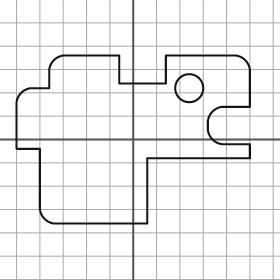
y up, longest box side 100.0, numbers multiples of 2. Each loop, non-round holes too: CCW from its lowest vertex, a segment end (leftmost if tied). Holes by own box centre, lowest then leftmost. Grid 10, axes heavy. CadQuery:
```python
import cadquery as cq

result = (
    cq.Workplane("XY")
    .moveTo(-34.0, -36.0)
    .lineTo(6.0, -36.0)
    .lineTo(6.0, -8.0)
    .lineTo(50.0, -8.0)
    .lineTo(50.0, -2.0)
    .lineTo(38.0, -2.0)
    .threePointArc((34.0, 0.0), (32.0, 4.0))
    .lineTo(32.0, 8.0)
    .threePointArc((34.0, 12.0), (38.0, 14.0))
    .lineTo(50.0, 14.0)
    .lineTo(50.0, 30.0)
    .threePointArc((48.0, 34.0), (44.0, 36.0))
    .lineTo(14.0, 36.0)
    .lineTo(14.0, 24.0)
    .lineTo(-6.0, 24.0)
    .lineTo(-6.0, 36.0)
    .lineTo(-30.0, 36.0)
    .threePointArc((-34.0, 34.0), (-36.0, 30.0))
    .lineTo(-36.0, 22.0)
    .lineTo(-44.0, 22.0)
    .threePointArc((-48.0, 20.0), (-50.0, 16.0))
    .lineTo(-50.0, -4.0)
    .lineTo(-40.0, -4.0)
    .lineTo(-40.0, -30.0)
    .threePointArc((-38.0, -34.0), (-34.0, -36.0))
    .close()
    .moveTo(24.0, 22.0)
    .circle(6.0)
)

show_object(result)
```